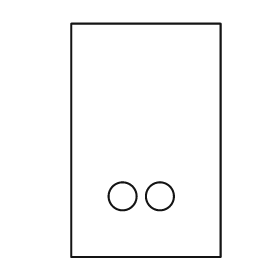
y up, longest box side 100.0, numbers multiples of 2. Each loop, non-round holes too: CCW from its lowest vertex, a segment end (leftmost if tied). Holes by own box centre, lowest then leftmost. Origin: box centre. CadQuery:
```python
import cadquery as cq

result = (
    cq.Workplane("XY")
    .moveTo(-32.0, -50.0)
    .lineTo(32.0, -50.0)
    .lineTo(32.0, 50.0)
    .lineTo(-32.0, 50.0)
    .close()
    .moveTo(-10.0, -24.0)
    .circle(6.0)
    .moveTo(6.0, -24.0)
    .circle(6.0)
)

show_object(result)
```